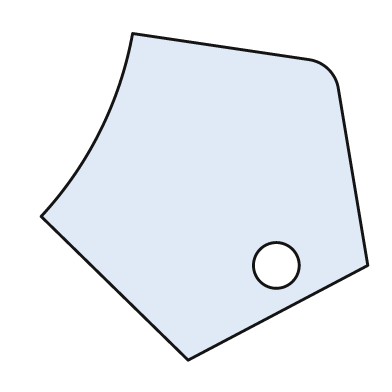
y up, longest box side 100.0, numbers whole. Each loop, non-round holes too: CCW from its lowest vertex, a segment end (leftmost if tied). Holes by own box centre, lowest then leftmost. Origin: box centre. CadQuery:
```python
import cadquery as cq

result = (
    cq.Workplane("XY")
    .moveTo(-5.0, -50.0)
    .lineTo(50.0, -21.0)
    .lineTo(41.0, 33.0)
    .threePointArc((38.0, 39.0), (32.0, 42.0))
    .lineTo(-22.0, 50.0)
    .threePointArc((-32.0, 20.0), (-50.0, -6.0))
    .close()
    .moveTo(22.0, -21.0)
    .circle(7.0)
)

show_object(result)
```